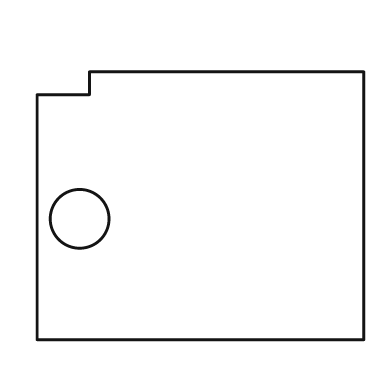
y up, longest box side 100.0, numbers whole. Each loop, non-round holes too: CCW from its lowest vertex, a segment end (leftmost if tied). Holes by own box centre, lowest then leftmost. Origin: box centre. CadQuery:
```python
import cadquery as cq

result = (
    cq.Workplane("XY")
    .moveTo(-50.0, -41.0)
    .lineTo(50.0, -41.0)
    .lineTo(50.0, 41.0)
    .lineTo(-34.0, 41.0)
    .lineTo(-34.0, 34.0)
    .lineTo(-50.0, 34.0)
    .close()
    .moveTo(-37.0, -4.0)
    .circle(9.0)
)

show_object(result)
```